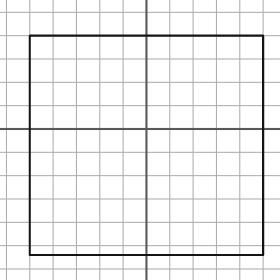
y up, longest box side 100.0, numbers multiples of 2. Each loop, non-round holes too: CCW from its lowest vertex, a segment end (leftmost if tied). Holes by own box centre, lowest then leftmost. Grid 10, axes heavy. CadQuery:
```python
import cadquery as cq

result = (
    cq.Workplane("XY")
    .moveTo(-50.0, -54.0)
    .lineTo(50.0, -54.0)
    .lineTo(50.0, 40.0)
    .lineTo(-50.0, 40.0)
    .close()
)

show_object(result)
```